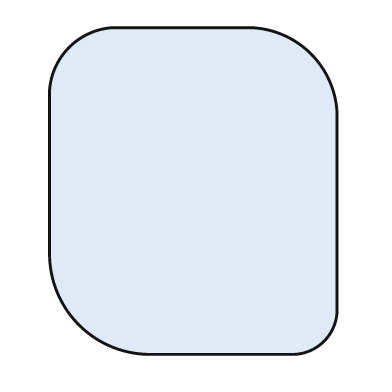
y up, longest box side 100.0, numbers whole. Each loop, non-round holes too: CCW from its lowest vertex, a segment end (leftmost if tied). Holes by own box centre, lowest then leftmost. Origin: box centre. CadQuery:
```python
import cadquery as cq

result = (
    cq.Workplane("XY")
    .moveTo(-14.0, -50.0)
    .lineTo(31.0, -50.0)
    .threePointArc((40.0, -46.0), (44.0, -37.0))
    .lineTo(44.0, 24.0)
    .threePointArc((36.0, 42.0), (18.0, 50.0))
    .lineTo(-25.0, 50.0)
    .threePointArc((-38.0, 44.0), (-44.0, 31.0))
    .lineTo(-44.0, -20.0)
    .threePointArc((-35.0, -41.0), (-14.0, -50.0))
    .close()
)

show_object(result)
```